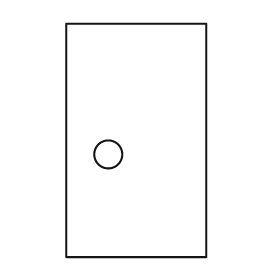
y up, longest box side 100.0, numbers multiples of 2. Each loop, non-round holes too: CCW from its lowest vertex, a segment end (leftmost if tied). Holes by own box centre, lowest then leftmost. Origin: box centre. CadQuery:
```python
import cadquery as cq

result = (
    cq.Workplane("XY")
    .moveTo(-30.0, -50.0)
    .lineTo(30.0, -50.0)
    .lineTo(30.0, 50.0)
    .lineTo(-30.0, 50.0)
    .close()
    .moveTo(-12.0, -6.0)
    .circle(6.0)
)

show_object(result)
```